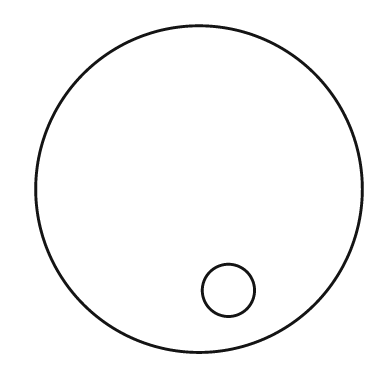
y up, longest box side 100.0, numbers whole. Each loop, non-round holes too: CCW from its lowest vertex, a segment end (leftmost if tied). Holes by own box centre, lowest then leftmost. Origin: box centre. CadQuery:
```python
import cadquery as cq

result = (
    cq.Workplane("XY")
    .moveTo(0.0, 0.0)
    .circle(50.0)
    .moveTo(9.0, -31.0)
    .circle(8.0)
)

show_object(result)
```